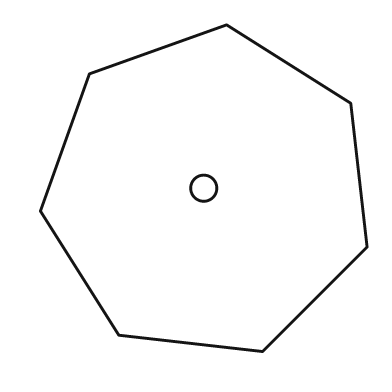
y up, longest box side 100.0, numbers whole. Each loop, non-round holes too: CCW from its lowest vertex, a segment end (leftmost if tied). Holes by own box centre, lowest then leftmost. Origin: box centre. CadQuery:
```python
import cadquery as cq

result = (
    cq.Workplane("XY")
    .moveTo(18.0, -50.0)
    .lineTo(50.0, -18.0)
    .lineTo(45.0, 26.0)
    .lineTo(7.0, 50.0)
    .lineTo(-35.0, 35.0)
    .lineTo(-50.0, -7.0)
    .lineTo(-26.0, -45.0)
    .close()
    .moveTo(0.0, 0.0)
    .circle(4.0)
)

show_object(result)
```